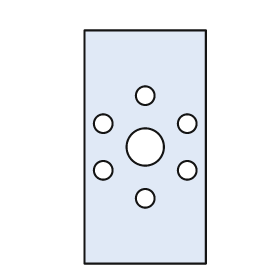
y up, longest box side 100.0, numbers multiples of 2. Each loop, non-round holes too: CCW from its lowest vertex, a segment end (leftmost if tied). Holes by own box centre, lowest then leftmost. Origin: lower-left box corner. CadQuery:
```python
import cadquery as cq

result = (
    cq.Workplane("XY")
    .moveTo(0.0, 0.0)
    .lineTo(52.0, 0.0)
    .lineTo(52.0, 100.0)
    .lineTo(0.0, 100.0)
    .close()
    .moveTo(26.0, 28.0)
    .circle(4.0)
    .moveTo(8.0, 40.0)
    .circle(4.0)
    .moveTo(44.0, 40.0)
    .circle(4.0)
    .moveTo(26.0, 50.0)
    .circle(8.0)
    .moveTo(8.0, 60.0)
    .circle(4.0)
    .moveTo(44.0, 60.0)
    .circle(4.0)
    .moveTo(26.0, 72.0)
    .circle(4.0)
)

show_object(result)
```